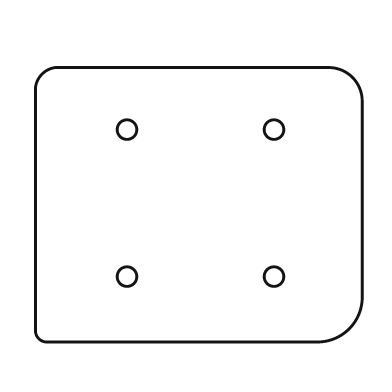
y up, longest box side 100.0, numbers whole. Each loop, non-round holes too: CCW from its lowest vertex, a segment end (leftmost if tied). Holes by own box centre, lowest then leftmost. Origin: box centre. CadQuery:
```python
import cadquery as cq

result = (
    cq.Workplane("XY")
    .moveTo(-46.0, -42.0)
    .lineTo(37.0, -42.0)
    .threePointArc((46.0, -38.0), (50.0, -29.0))
    .lineTo(50.0, 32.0)
    .threePointArc((47.0, 39.0), (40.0, 42.0))
    .lineTo(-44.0, 42.0)
    .threePointArc((-48.0, 40.0), (-50.0, 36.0))
    .lineTo(-50.0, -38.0)
    .threePointArc((-49.0, -41.0), (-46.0, -42.0))
    .close()
    .moveTo(-22.0, -22.0)
    .circle(3.0)
    .moveTo(23.0, -22.0)
    .circle(3.0)
    .moveTo(-22.0, 23.0)
    .circle(3.0)
    .moveTo(23.0, 23.0)
    .circle(3.0)
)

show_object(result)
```